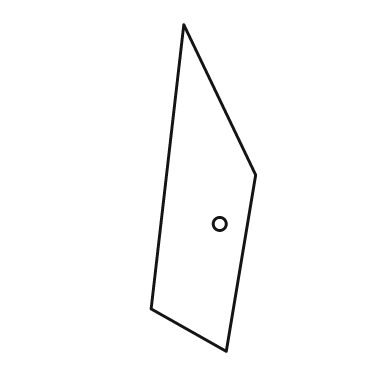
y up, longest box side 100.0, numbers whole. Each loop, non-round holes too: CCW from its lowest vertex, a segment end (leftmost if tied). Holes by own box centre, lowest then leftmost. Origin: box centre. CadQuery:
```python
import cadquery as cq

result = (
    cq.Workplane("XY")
    .moveTo(7.0, -50.0)
    .lineTo(16.0, 4.0)
    .lineTo(-6.0, 50.0)
    .lineTo(-16.0, -37.0)
    .close()
    .moveTo(5.0, -11.0)
    .circle(2.0)
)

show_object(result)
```